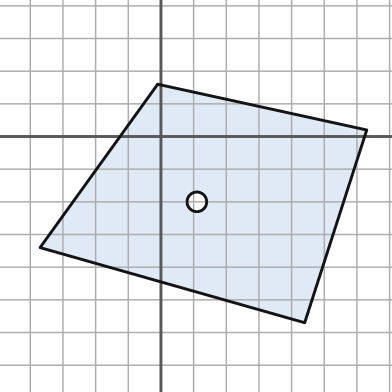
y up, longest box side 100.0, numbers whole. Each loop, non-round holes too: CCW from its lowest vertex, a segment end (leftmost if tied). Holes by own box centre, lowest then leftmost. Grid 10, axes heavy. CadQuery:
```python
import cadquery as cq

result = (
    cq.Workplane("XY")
    .moveTo(44.0, -57.0)
    .lineTo(63.0, 2.0)
    .lineTo(-1.0, 16.0)
    .lineTo(-37.0, -34.0)
    .close()
    .moveTo(11.0, -20.0)
    .circle(3.0)
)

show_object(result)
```